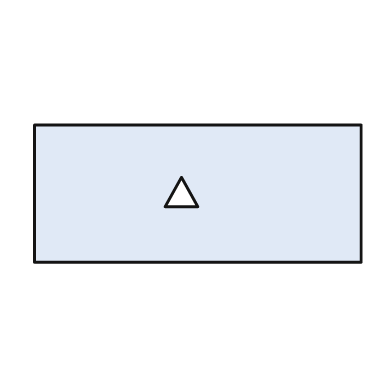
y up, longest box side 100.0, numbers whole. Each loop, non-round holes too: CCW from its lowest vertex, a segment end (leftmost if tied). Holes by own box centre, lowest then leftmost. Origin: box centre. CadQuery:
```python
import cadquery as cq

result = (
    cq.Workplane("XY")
    .moveTo(-50.0, -21.0)
    .lineTo(50.0, -21.0)
    .lineTo(50.0, 21.0)
    .lineTo(-50.0, 21.0)
    .close()
    .moveTo(-10.0, -4.0)
    .lineTo(0.0, -4.0)
    .lineTo(-5.0, 5.0)
    .close()
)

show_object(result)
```